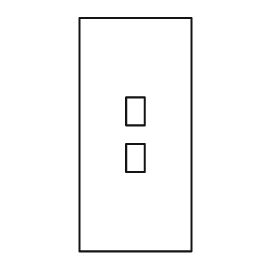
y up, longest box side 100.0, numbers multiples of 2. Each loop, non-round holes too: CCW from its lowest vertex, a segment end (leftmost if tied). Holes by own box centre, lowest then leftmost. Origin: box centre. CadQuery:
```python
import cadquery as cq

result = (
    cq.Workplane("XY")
    .moveTo(-24.0, -50.0)
    .lineTo(24.0, -50.0)
    .lineTo(24.0, 50.0)
    .lineTo(-24.0, 50.0)
    .close()
    .moveTo(-4.0, -16.0)
    .lineTo(4.0, -16.0)
    .lineTo(4.0, -4.0)
    .lineTo(-4.0, -4.0)
    .close()
    .moveTo(-4.0, 4.0)
    .lineTo(4.0, 4.0)
    .lineTo(4.0, 16.0)
    .lineTo(-4.0, 16.0)
    .close()
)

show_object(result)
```